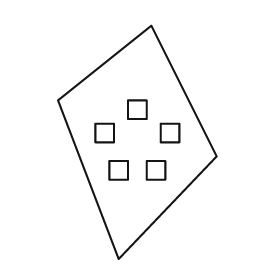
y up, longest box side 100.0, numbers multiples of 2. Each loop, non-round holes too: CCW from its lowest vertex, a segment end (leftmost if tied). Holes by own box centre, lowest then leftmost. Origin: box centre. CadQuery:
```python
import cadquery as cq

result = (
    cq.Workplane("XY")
    .moveTo(-8.0, -50.0)
    .lineTo(34.0, -6.0)
    .lineTo(6.0, 50.0)
    .lineTo(-34.0, 18.0)
    .close()
    .moveTo(-12.0, -16.0)
    .lineTo(-4.0, -16.0)
    .lineTo(-4.0, -8.0)
    .lineTo(-12.0, -8.0)
    .close()
    .moveTo(4.0, -16.0)
    .lineTo(12.0, -16.0)
    .lineTo(12.0, -8.0)
    .lineTo(4.0, -8.0)
    .close()
    .moveTo(-18.0, 0.0)
    .lineTo(-10.0, 0.0)
    .lineTo(-10.0, 8.0)
    .lineTo(-18.0, 8.0)
    .close()
    .moveTo(10.0, 0.0)
    .lineTo(18.0, 0.0)
    .lineTo(18.0, 8.0)
    .lineTo(10.0, 8.0)
    .close()
    .moveTo(-4.0, 10.0)
    .lineTo(4.0, 10.0)
    .lineTo(4.0, 18.0)
    .lineTo(-4.0, 18.0)
    .close()
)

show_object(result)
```